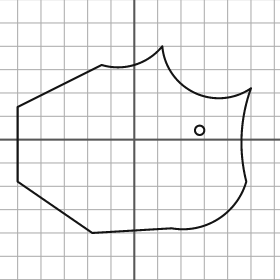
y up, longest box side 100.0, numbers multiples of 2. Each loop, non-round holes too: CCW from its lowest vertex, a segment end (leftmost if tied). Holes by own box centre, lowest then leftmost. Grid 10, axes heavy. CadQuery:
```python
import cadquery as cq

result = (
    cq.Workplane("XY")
    .moveTo(-18.0, -40.0)
    .lineTo(16.0, -38.0)
    .threePointArc((36.0, -34.0), (48.0, -18.0))
    .threePointArc((46.0, 2.0), (50.0, 22.0))
    .threePointArc((26.0, 20.0), (12.0, 40.0))
    .threePointArc((0.0, 32.0), (-14.0, 32.0))
    .lineTo(-50.0, 14.0)
    .lineTo(-50.0, -18.0)
    .close()
    .moveTo(28.0, 4.0)
    .circle(2.0)
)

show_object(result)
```